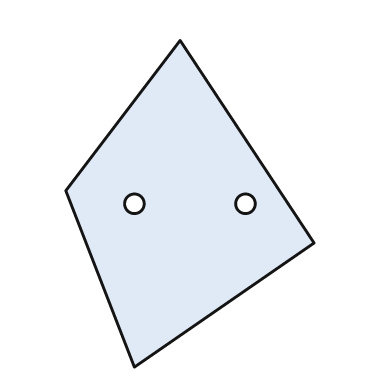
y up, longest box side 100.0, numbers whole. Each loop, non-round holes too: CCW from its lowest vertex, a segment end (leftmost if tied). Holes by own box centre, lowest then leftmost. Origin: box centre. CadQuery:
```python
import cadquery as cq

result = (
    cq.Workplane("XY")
    .moveTo(-17.0, -50.0)
    .lineTo(38.0, -12.0)
    .lineTo(-3.0, 50.0)
    .lineTo(-38.0, 4.0)
    .close()
    .moveTo(-17.0, 0.0)
    .circle(3.0)
    .moveTo(17.0, 0.0)
    .circle(3.0)
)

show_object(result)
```